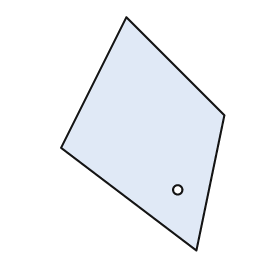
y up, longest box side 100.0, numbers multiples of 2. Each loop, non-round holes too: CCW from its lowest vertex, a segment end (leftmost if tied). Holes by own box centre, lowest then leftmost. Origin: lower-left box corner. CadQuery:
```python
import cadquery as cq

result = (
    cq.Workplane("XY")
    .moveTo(58.0, 0.0)
    .lineTo(70.0, 58.0)
    .lineTo(28.0, 100.0)
    .lineTo(0.0, 44.0)
    .close()
    .moveTo(50.0, 26.0)
    .circle(2.0)
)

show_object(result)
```